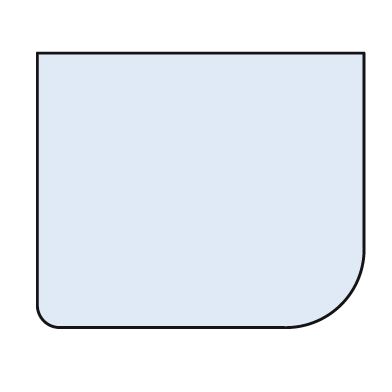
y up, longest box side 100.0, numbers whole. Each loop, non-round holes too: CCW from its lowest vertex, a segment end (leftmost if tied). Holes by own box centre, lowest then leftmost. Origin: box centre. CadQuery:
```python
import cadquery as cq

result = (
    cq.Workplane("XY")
    .moveTo(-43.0, -42.0)
    .lineTo(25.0, -42.0)
    .threePointArc((43.0, -35.0), (50.0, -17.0))
    .lineTo(50.0, 42.0)
    .lineTo(-50.0, 42.0)
    .lineTo(-50.0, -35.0)
    .threePointArc((-48.0, -40.0), (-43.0, -42.0))
    .close()
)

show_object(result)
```